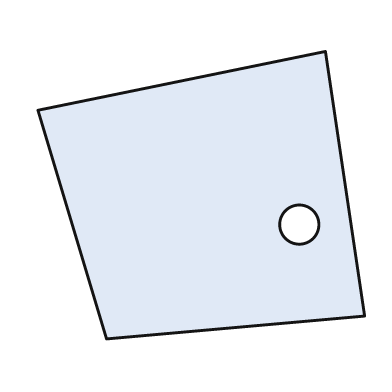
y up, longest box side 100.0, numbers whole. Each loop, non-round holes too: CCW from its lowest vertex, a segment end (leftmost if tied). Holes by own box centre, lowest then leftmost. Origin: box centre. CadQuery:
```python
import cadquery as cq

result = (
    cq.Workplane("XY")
    .moveTo(-29.0, -44.0)
    .lineTo(50.0, -37.0)
    .lineTo(38.0, 44.0)
    .lineTo(-50.0, 26.0)
    .close()
    .moveTo(30.0, -9.0)
    .circle(6.0)
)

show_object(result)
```